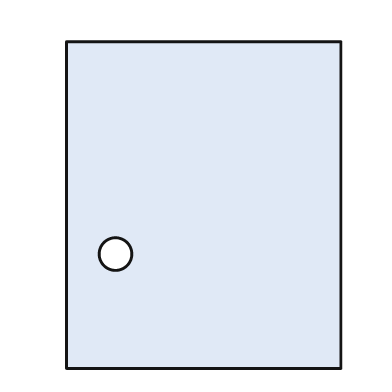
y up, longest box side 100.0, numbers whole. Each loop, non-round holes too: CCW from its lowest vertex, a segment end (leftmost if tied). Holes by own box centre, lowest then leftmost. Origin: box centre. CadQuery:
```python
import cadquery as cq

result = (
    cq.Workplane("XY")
    .moveTo(-42.0, -50.0)
    .lineTo(42.0, -50.0)
    .lineTo(42.0, 50.0)
    .lineTo(-42.0, 50.0)
    .close()
    .moveTo(-27.0, -15.0)
    .circle(5.0)
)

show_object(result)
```